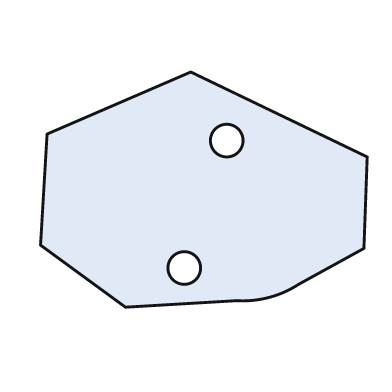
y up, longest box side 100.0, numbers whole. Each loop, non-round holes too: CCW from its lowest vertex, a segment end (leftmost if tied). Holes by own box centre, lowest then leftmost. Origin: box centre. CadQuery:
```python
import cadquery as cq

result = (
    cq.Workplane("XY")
    .moveTo(-24.0, -36.0)
    .lineTo(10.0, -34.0)
    .threePointArc((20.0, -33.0), (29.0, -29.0))
    .lineTo(49.0, -18.0)
    .lineTo(50.0, 10.0)
    .lineTo(-4.0, 36.0)
    .lineTo(-48.0, 17.0)
    .lineTo(-50.0, -17.0)
    .close()
    .moveTo(-6.0, -24.0)
    .circle(5.0)
    .moveTo(7.0, 15.0)
    .circle(5.0)
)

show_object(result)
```